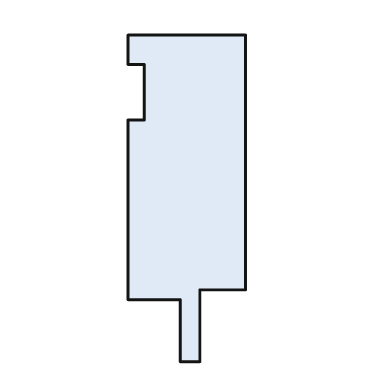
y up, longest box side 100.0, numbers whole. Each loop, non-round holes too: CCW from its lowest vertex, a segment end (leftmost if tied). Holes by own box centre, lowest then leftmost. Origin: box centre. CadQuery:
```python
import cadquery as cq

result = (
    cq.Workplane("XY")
    .moveTo(-2.0, -50.0)
    .lineTo(4.0, -50.0)
    .lineTo(4.0, -28.0)
    .lineTo(18.0, -28.0)
    .lineTo(18.0, 50.0)
    .lineTo(-18.0, 50.0)
    .lineTo(-18.0, 41.0)
    .lineTo(-13.0, 41.0)
    .lineTo(-13.0, 24.0)
    .lineTo(-18.0, 24.0)
    .lineTo(-18.0, -31.0)
    .lineTo(-2.0, -31.0)
    .close()
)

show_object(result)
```